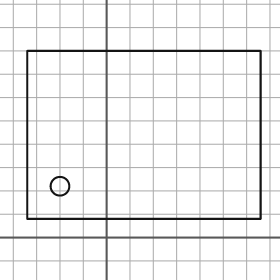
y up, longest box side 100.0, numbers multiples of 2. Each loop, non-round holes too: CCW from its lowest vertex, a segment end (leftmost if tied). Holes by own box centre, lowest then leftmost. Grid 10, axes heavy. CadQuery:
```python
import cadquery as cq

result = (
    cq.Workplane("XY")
    .moveTo(-34.0, 8.0)
    .lineTo(66.0, 8.0)
    .lineTo(66.0, 80.0)
    .lineTo(-34.0, 80.0)
    .close()
    .moveTo(-20.0, 22.0)
    .circle(4.0)
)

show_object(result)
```